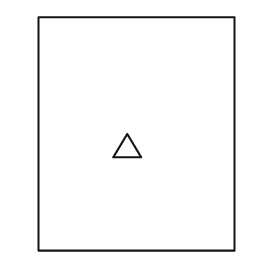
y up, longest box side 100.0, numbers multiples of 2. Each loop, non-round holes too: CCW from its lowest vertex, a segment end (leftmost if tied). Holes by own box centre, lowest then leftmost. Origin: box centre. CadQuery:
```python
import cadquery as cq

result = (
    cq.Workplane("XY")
    .moveTo(-42.0, -50.0)
    .lineTo(42.0, -50.0)
    .lineTo(42.0, 50.0)
    .lineTo(-42.0, 50.0)
    .close()
    .moveTo(-10.0, -10.0)
    .lineTo(2.0, -10.0)
    .lineTo(-4.0, 0.0)
    .close()
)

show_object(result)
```